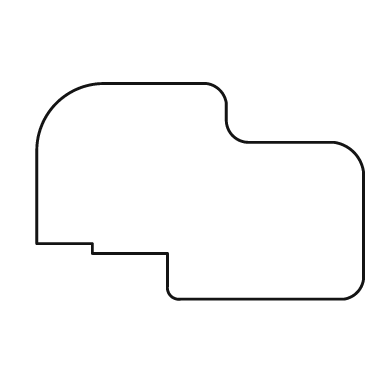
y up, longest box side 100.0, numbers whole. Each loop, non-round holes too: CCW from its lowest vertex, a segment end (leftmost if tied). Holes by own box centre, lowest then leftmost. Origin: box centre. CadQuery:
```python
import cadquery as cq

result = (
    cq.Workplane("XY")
    .moveTo(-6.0, -33.0)
    .lineTo(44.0, -33.0)
    .threePointArc((48.0, -31.0), (50.0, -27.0))
    .lineTo(50.0, 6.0)
    .threePointArc((47.0, 12.0), (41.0, 15.0))
    .lineTo(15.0, 15.0)
    .threePointArc((10.0, 17.0), (8.0, 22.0))
    .lineTo(8.0, 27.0)
    .threePointArc((6.0, 31.0), (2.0, 33.0))
    .lineTo(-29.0, 33.0)
    .threePointArc((-44.0, 27.0), (-50.0, 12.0))
    .lineTo(-50.0, -16.0)
    .lineTo(-33.0, -16.0)
    .lineTo(-33.0, -19.0)
    .lineTo(-10.0, -19.0)
    .lineTo(-10.0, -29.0)
    .threePointArc((-9.0, -32.0), (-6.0, -33.0))
    .close()
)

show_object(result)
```